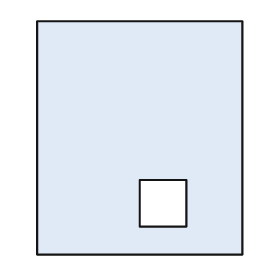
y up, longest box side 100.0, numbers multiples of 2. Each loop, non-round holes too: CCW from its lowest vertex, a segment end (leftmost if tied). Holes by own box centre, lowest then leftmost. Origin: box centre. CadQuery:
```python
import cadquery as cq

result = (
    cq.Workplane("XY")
    .moveTo(-44.0, -50.0)
    .lineTo(44.0, -50.0)
    .lineTo(44.0, 50.0)
    .lineTo(-44.0, 50.0)
    .close()
    .moveTo(0.0, -38.0)
    .lineTo(20.0, -38.0)
    .lineTo(20.0, -18.0)
    .lineTo(0.0, -18.0)
    .close()
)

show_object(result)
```